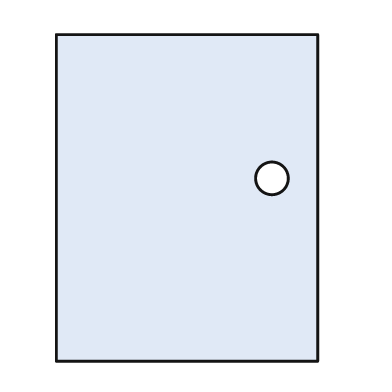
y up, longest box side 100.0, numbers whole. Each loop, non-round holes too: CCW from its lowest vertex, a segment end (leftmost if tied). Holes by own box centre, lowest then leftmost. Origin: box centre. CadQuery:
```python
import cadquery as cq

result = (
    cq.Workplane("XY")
    .moveTo(-40.0, -50.0)
    .lineTo(40.0, -50.0)
    .lineTo(40.0, 50.0)
    .lineTo(-40.0, 50.0)
    .close()
    .moveTo(26.0, 6.0)
    .circle(5.0)
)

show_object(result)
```